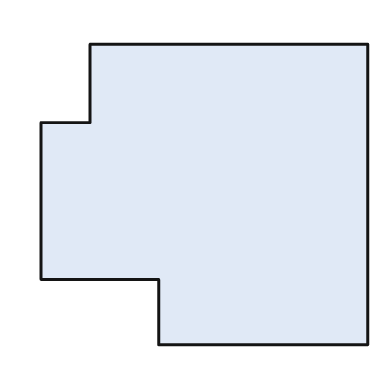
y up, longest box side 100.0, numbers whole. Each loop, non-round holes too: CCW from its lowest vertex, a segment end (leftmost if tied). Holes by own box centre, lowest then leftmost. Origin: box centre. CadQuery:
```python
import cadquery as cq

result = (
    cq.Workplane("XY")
    .moveTo(-14.0, -46.0)
    .lineTo(50.0, -46.0)
    .lineTo(50.0, 46.0)
    .lineTo(-35.0, 46.0)
    .lineTo(-35.0, 22.0)
    .lineTo(-50.0, 22.0)
    .lineTo(-50.0, -26.0)
    .lineTo(-14.0, -26.0)
    .close()
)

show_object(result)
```